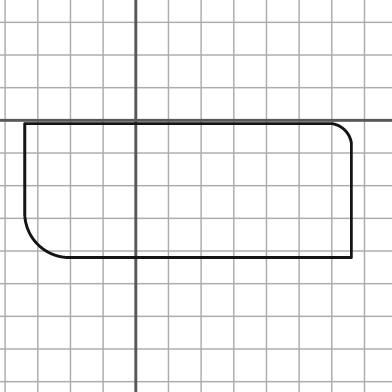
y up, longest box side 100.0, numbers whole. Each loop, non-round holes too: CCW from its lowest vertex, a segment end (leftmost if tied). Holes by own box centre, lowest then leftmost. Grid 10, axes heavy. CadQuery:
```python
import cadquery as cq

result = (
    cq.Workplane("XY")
    .moveTo(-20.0, -42.0)
    .lineTo(66.0, -42.0)
    .lineTo(66.0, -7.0)
    .threePointArc((64.0, -3.0), (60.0, -1.0))
    .lineTo(-34.0, -1.0)
    .lineTo(-34.0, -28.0)
    .threePointArc((-30.0, -38.0), (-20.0, -42.0))
    .close()
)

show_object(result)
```